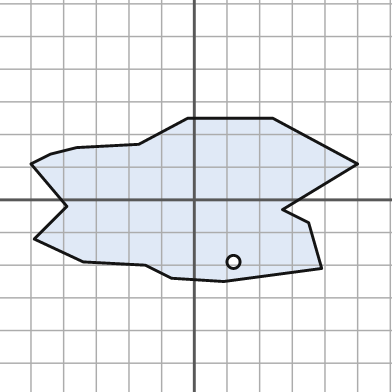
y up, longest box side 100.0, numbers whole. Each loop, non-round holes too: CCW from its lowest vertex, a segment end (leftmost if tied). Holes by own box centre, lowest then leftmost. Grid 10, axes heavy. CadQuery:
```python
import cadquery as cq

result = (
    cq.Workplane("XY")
    .moveTo(9.0, -25.0)
    .lineTo(39.0, -21.0)
    .lineTo(35.0, -7.0)
    .lineTo(27.0, -3.0)
    .lineTo(50.0, 11.0)
    .lineTo(24.0, 25.0)
    .lineTo(-2.0, 25.0)
    .lineTo(-17.0, 17.0)
    .lineTo(-36.0, 16.0)
    .lineTo(-44.0, 14.0)
    .lineTo(-50.0, 11.0)
    .lineTo(-39.0, -2.0)
    .lineTo(-49.0, -12.0)
    .lineTo(-34.0, -19.0)
    .lineTo(-15.0, -20.0)
    .lineTo(-7.0, -24.0)
    .close()
    .moveTo(12.0, -19.0)
    .circle(2.0)
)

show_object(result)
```